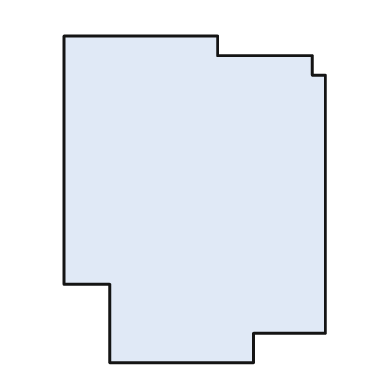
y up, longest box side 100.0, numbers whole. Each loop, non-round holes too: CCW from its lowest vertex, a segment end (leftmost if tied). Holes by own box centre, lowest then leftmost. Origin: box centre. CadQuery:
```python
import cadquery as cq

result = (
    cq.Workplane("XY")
    .moveTo(-26.0, -50.0)
    .lineTo(18.0, -50.0)
    .lineTo(18.0, -41.0)
    .lineTo(40.0, -41.0)
    .lineTo(40.0, 38.0)
    .lineTo(36.0, 38.0)
    .lineTo(36.0, 44.0)
    .lineTo(7.0, 44.0)
    .lineTo(7.0, 50.0)
    .lineTo(-40.0, 50.0)
    .lineTo(-40.0, -26.0)
    .lineTo(-26.0, -26.0)
    .close()
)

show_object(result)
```